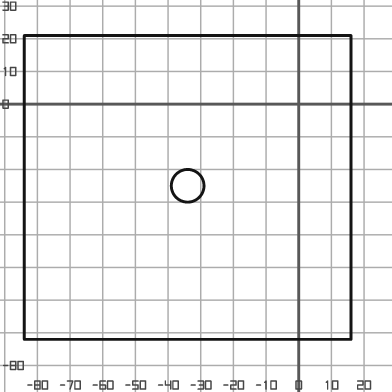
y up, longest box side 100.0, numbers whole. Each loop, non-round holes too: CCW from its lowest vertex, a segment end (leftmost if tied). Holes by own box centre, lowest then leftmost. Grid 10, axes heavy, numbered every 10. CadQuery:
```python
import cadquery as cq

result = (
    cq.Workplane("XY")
    .moveTo(-84.0, -72.0)
    .lineTo(16.0, -72.0)
    .lineTo(16.0, 21.0)
    .lineTo(-84.0, 21.0)
    .close()
    .moveTo(-34.0, -25.0)
    .circle(5.0)
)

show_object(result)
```